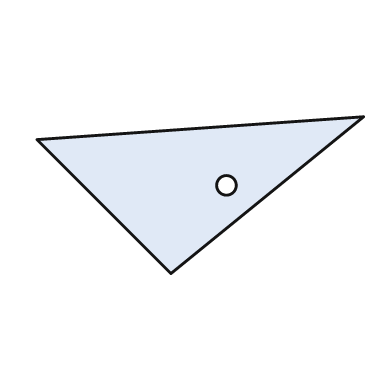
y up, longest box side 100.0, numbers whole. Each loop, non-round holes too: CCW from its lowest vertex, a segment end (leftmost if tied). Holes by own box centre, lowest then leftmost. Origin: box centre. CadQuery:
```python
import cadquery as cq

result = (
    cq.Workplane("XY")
    .moveTo(-9.0, -24.0)
    .lineTo(50.0, 24.0)
    .lineTo(-50.0, 17.0)
    .close()
    .moveTo(8.0, 3.0)
    .circle(3.0)
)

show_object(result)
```